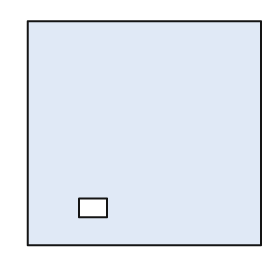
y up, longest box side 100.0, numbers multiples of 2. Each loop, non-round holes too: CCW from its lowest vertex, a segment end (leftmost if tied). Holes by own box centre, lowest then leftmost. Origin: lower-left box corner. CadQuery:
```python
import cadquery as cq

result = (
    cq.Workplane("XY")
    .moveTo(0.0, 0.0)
    .lineTo(100.0, 0.0)
    .lineTo(100.0, 96.0)
    .lineTo(0.0, 96.0)
    .close()
    .moveTo(22.0, 12.0)
    .lineTo(34.0, 12.0)
    .lineTo(34.0, 20.0)
    .lineTo(22.0, 20.0)
    .close()
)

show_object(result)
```